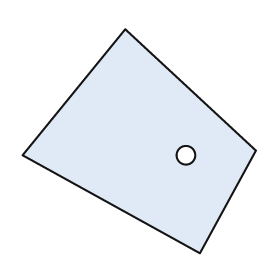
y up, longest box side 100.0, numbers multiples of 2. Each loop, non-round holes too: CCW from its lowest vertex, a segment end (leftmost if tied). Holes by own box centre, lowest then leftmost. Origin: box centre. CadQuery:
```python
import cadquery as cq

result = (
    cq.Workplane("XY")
    .moveTo(26.0, -48.0)
    .lineTo(50.0, -4.0)
    .lineTo(-6.0, 48.0)
    .lineTo(-50.0, -6.0)
    .close()
    .moveTo(20.0, -6.0)
    .circle(4.0)
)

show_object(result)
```